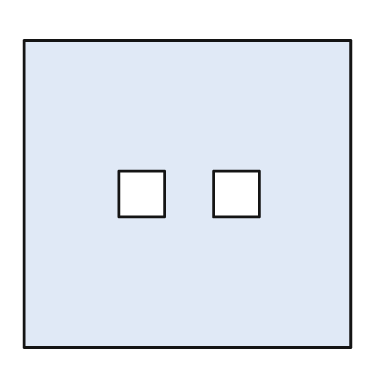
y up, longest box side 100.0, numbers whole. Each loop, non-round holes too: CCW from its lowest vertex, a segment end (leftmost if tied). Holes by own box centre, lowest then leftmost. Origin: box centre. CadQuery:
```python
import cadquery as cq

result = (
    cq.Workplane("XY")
    .moveTo(-50.0, -47.0)
    .lineTo(50.0, -47.0)
    .lineTo(50.0, 47.0)
    .lineTo(-50.0, 47.0)
    .close()
    .moveTo(-21.0, -7.0)
    .lineTo(-7.0, -7.0)
    .lineTo(-7.0, 7.0)
    .lineTo(-21.0, 7.0)
    .close()
    .moveTo(8.0, -7.0)
    .lineTo(22.0, -7.0)
    .lineTo(22.0, 7.0)
    .lineTo(8.0, 7.0)
    .close()
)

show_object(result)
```